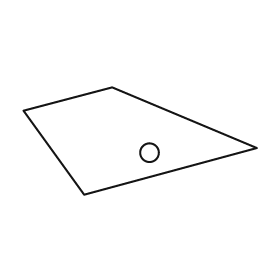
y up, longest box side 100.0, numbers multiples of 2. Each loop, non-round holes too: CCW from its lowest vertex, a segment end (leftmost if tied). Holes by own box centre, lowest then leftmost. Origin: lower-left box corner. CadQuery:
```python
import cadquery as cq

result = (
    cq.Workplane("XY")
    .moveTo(26.0, 0.0)
    .lineTo(100.0, 20.0)
    .lineTo(38.0, 46.0)
    .lineTo(0.0, 36.0)
    .close()
    .moveTo(54.0, 18.0)
    .circle(4.0)
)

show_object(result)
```